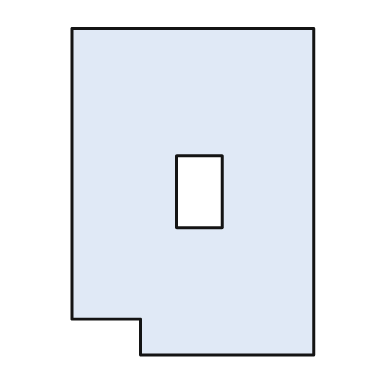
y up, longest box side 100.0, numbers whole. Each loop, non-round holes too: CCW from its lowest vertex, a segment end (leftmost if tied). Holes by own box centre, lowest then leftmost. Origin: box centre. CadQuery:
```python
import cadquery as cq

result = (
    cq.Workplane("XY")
    .moveTo(-16.0, -50.0)
    .lineTo(37.0, -50.0)
    .lineTo(37.0, 50.0)
    .lineTo(-37.0, 50.0)
    .lineTo(-37.0, -39.0)
    .lineTo(-16.0, -39.0)
    .close()
    .moveTo(-5.0, -11.0)
    .lineTo(9.0, -11.0)
    .lineTo(9.0, 11.0)
    .lineTo(-5.0, 11.0)
    .close()
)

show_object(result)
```